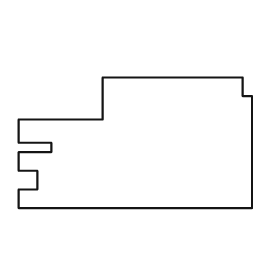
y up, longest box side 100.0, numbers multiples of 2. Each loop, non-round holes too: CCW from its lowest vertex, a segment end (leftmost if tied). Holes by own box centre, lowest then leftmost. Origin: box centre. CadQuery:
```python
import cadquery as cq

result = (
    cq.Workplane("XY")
    .moveTo(-50.0, -28.0)
    .lineTo(50.0, -28.0)
    .lineTo(50.0, 20.0)
    .lineTo(46.0, 20.0)
    .lineTo(46.0, 28.0)
    .lineTo(-14.0, 28.0)
    .lineTo(-14.0, 10.0)
    .lineTo(-50.0, 10.0)
    .lineTo(-50.0, 0.0)
    .lineTo(-36.0, 0.0)
    .lineTo(-36.0, -4.0)
    .lineTo(-50.0, -4.0)
    .lineTo(-50.0, -12.0)
    .lineTo(-42.0, -12.0)
    .lineTo(-42.0, -20.0)
    .lineTo(-50.0, -20.0)
    .close()
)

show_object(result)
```